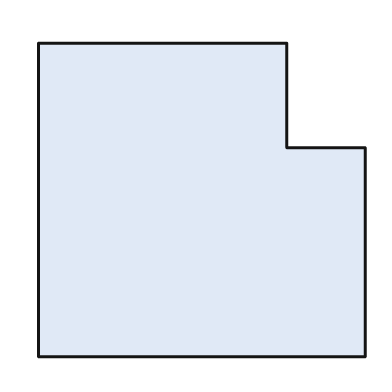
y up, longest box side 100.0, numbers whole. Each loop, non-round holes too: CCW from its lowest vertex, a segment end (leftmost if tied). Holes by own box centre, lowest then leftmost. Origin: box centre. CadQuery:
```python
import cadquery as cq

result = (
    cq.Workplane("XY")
    .moveTo(-50.0, -48.0)
    .lineTo(50.0, -48.0)
    .lineTo(50.0, 16.0)
    .lineTo(26.0, 16.0)
    .lineTo(26.0, 48.0)
    .lineTo(-50.0, 48.0)
    .close()
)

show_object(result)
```